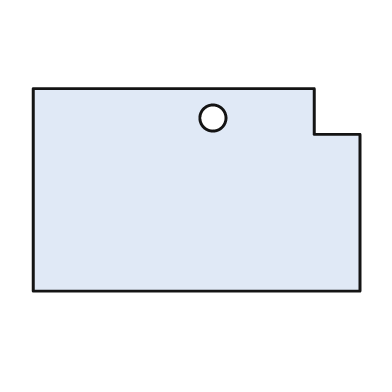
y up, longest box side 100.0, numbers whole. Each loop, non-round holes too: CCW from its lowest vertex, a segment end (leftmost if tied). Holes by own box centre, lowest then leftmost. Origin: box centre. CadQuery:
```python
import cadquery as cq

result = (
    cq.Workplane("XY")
    .moveTo(-50.0, -31.0)
    .lineTo(50.0, -31.0)
    .lineTo(50.0, 17.0)
    .lineTo(36.0, 17.0)
    .lineTo(36.0, 31.0)
    .lineTo(-50.0, 31.0)
    .close()
    .moveTo(5.0, 22.0)
    .circle(4.0)
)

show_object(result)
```